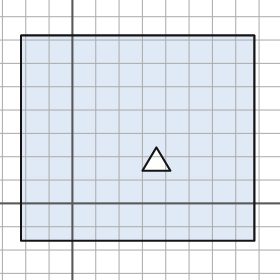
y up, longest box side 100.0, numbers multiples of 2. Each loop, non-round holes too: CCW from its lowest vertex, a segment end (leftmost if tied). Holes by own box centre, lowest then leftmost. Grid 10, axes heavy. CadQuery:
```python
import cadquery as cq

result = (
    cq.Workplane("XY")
    .moveTo(-22.0, -16.0)
    .lineTo(78.0, -16.0)
    .lineTo(78.0, 72.0)
    .lineTo(-22.0, 72.0)
    .close()
    .moveTo(30.0, 14.0)
    .lineTo(42.0, 14.0)
    .lineTo(36.0, 24.0)
    .close()
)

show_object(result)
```